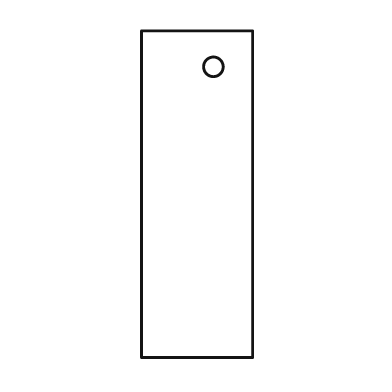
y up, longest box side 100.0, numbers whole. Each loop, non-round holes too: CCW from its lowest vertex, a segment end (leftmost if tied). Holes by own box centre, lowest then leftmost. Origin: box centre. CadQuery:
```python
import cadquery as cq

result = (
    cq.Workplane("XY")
    .moveTo(-17.0, -50.0)
    .lineTo(17.0, -50.0)
    .lineTo(17.0, 50.0)
    .lineTo(-17.0, 50.0)
    .close()
    .moveTo(5.0, 39.0)
    .circle(3.0)
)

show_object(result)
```